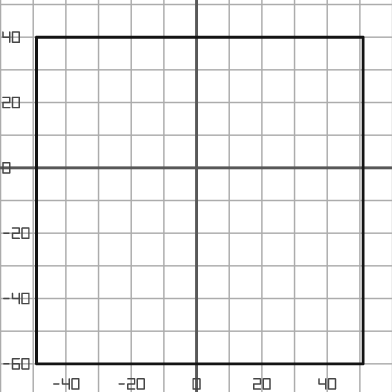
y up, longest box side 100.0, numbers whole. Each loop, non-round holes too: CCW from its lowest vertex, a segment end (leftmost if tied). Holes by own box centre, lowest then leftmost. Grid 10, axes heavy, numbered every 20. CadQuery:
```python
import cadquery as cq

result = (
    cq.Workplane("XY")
    .moveTo(-49.0, -60.0)
    .lineTo(51.0, -60.0)
    .lineTo(51.0, 40.0)
    .lineTo(-49.0, 40.0)
    .close()
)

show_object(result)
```